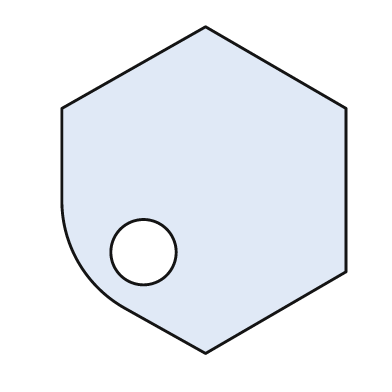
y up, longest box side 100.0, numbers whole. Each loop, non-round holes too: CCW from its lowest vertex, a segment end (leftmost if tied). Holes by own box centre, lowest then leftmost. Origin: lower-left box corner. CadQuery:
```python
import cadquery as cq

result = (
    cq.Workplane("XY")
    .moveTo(44.0, 0.0)
    .lineTo(87.0, 25.0)
    .lineTo(87.0, 75.0)
    .lineTo(44.0, 100.0)
    .lineTo(0.0, 75.0)
    .lineTo(0.0, 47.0)
    .threePointArc((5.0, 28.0), (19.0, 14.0))
    .close()
    .moveTo(25.0, 31.0)
    .circle(10.0)
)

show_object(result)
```